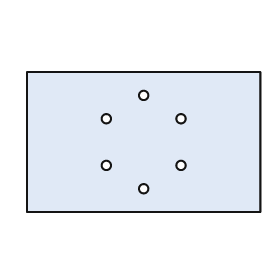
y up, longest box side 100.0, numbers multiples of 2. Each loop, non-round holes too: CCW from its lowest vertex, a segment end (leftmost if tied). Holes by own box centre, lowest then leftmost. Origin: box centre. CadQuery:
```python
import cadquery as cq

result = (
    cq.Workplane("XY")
    .moveTo(-50.0, -30.0)
    .lineTo(50.0, -30.0)
    .lineTo(50.0, 30.0)
    .lineTo(-50.0, 30.0)
    .close()
    .moveTo(0.0, -20.0)
    .circle(2.0)
    .moveTo(-16.0, -10.0)
    .circle(2.0)
    .moveTo(16.0, -10.0)
    .circle(2.0)
    .moveTo(-16.0, 10.0)
    .circle(2.0)
    .moveTo(16.0, 10.0)
    .circle(2.0)
    .moveTo(0.0, 20.0)
    .circle(2.0)
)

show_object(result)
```